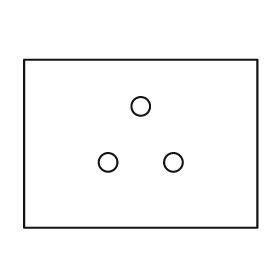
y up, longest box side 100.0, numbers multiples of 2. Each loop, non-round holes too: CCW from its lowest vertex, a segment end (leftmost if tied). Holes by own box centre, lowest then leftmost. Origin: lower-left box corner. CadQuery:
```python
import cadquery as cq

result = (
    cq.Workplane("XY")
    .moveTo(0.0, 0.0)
    .lineTo(100.0, 0.0)
    .lineTo(100.0, 72.0)
    .lineTo(0.0, 72.0)
    .close()
    .moveTo(36.0, 28.0)
    .circle(4.0)
    .moveTo(64.0, 28.0)
    .circle(4.0)
    .moveTo(50.0, 52.0)
    .circle(4.0)
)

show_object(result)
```